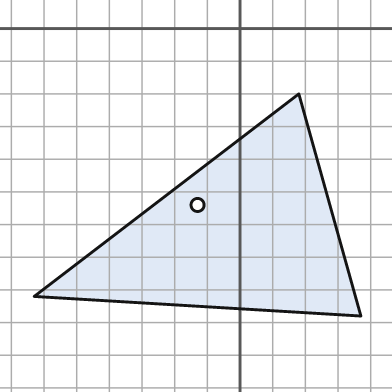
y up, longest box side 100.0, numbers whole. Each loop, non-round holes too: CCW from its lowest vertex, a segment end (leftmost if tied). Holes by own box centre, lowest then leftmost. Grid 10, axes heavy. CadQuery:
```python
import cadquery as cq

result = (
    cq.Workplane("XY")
    .moveTo(37.0, -88.0)
    .lineTo(18.0, -20.0)
    .lineTo(-63.0, -82.0)
    .close()
    .moveTo(-13.0, -54.0)
    .circle(2.0)
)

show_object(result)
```